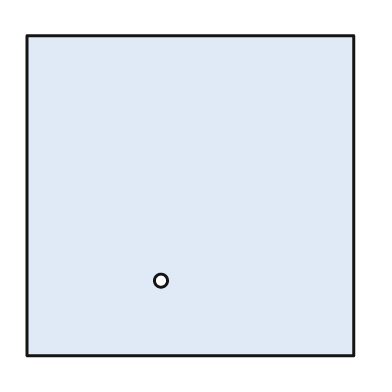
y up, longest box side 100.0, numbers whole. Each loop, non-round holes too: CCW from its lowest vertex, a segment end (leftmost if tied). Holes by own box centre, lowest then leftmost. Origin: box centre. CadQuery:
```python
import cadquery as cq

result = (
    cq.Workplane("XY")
    .moveTo(-50.0, -49.0)
    .lineTo(50.0, -49.0)
    .lineTo(50.0, 49.0)
    .lineTo(-50.0, 49.0)
    .close()
    .moveTo(-9.0, -26.0)
    .circle(2.0)
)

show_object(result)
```